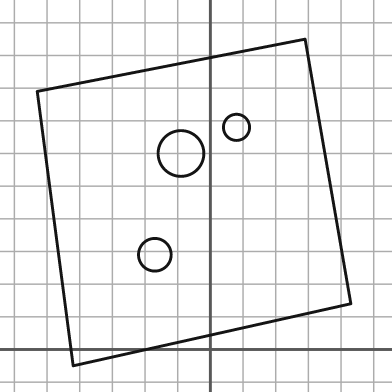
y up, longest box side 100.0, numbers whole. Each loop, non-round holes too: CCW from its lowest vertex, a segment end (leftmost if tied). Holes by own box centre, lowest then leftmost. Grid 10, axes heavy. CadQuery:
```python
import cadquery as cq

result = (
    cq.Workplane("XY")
    .moveTo(-42.0, -5.0)
    .lineTo(43.0, 14.0)
    .lineTo(29.0, 95.0)
    .lineTo(-53.0, 79.0)
    .close()
    .moveTo(-17.0, 29.0)
    .circle(5.0)
    .moveTo(-9.0, 60.0)
    .circle(7.0)
    .moveTo(8.0, 68.0)
    .circle(4.0)
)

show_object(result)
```